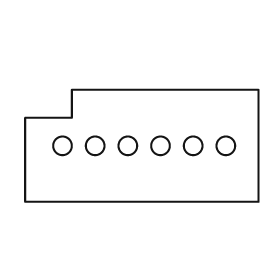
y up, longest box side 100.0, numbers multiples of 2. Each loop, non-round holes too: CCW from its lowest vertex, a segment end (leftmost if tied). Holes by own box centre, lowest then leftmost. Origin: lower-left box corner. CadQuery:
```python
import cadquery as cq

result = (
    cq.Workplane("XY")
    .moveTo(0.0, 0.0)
    .lineTo(100.0, 0.0)
    .lineTo(100.0, 48.0)
    .lineTo(20.0, 48.0)
    .lineTo(20.0, 36.0)
    .lineTo(0.0, 36.0)
    .close()
    .moveTo(16.0, 24.0)
    .circle(4.0)
    .moveTo(30.0, 24.0)
    .circle(4.0)
    .moveTo(44.0, 24.0)
    .circle(4.0)
    .moveTo(58.0, 24.0)
    .circle(4.0)
    .moveTo(72.0, 24.0)
    .circle(4.0)
    .moveTo(86.0, 24.0)
    .circle(4.0)
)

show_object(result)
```